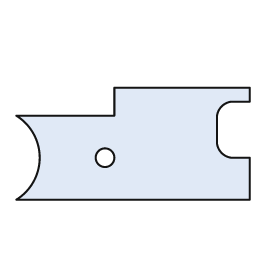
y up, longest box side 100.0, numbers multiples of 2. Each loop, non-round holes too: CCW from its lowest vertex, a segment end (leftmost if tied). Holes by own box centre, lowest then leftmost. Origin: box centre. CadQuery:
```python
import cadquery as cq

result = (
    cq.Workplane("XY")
    .moveTo(-50.0, -24.0)
    .lineTo(50.0, -24.0)
    .lineTo(50.0, -6.0)
    .lineTo(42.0, -6.0)
    .threePointArc((38.0, -4.0), (36.0, 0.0))
    .lineTo(36.0, 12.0)
    .threePointArc((38.0, 16.0), (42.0, 18.0))
    .lineTo(50.0, 18.0)
    .lineTo(50.0, 24.0)
    .lineTo(-8.0, 24.0)
    .lineTo(-8.0, 12.0)
    .lineTo(-50.0, 12.0)
    .threePointArc((-40.0, -6.0), (-50.0, -24.0))
    .close()
    .moveTo(-12.0, -6.0)
    .circle(4.0)
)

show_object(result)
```